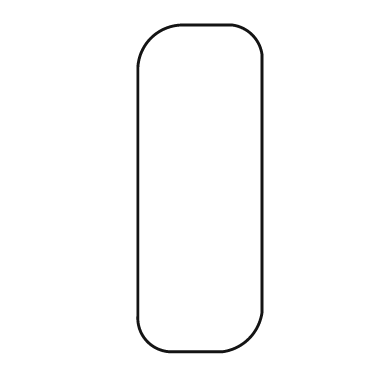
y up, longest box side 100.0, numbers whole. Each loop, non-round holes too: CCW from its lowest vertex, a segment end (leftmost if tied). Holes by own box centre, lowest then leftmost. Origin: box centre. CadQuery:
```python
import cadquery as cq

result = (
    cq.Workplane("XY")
    .moveTo(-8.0, -50.0)
    .lineTo(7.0, -50.0)
    .threePointArc((15.0, -46.0), (19.0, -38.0))
    .lineTo(19.0, 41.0)
    .threePointArc((16.0, 47.0), (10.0, 50.0))
    .lineTo(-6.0, 50.0)
    .threePointArc((-15.0, 46.0), (-19.0, 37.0))
    .lineTo(-19.0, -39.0)
    .threePointArc((-16.0, -47.0), (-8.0, -50.0))
    .close()
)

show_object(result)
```